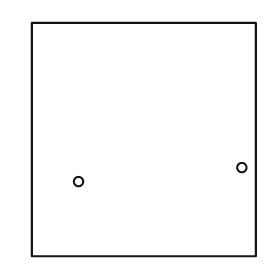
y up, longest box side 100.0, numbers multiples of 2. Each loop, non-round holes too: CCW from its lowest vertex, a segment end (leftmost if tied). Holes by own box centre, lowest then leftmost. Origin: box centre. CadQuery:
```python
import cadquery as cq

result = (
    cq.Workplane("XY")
    .moveTo(-48.0, -50.0)
    .lineTo(48.0, -50.0)
    .lineTo(48.0, 50.0)
    .lineTo(-48.0, 50.0)
    .close()
    .moveTo(-28.0, -18.0)
    .circle(2.0)
    .moveTo(42.0, -12.0)
    .circle(2.0)
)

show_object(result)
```